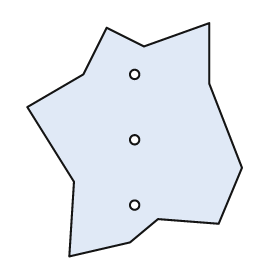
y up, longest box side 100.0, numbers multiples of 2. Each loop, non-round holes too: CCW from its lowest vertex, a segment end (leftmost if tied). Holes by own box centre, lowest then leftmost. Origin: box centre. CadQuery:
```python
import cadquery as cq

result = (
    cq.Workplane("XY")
    .moveTo(-28.0, -50.0)
    .lineTo(-2.0, -44.0)
    .lineTo(10.0, -34.0)
    .lineTo(36.0, -36.0)
    .lineTo(46.0, -12.0)
    .lineTo(32.0, 24.0)
    .lineTo(32.0, 50.0)
    .lineTo(4.0, 40.0)
    .lineTo(-12.0, 48.0)
    .lineTo(-22.0, 28.0)
    .lineTo(-46.0, 14.0)
    .lineTo(-26.0, -18.0)
    .close()
    .moveTo(0.0, -28.0)
    .circle(2.0)
    .moveTo(0.0, 0.0)
    .circle(2.0)
    .moveTo(0.0, 28.0)
    .circle(2.0)
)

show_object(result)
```